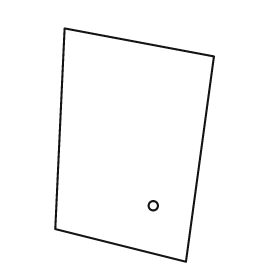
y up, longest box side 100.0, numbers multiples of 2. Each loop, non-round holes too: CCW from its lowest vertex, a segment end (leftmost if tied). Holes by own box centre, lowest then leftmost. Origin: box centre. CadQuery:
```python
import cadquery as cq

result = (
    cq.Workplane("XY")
    .moveTo(22.0, -50.0)
    .lineTo(34.0, 38.0)
    .lineTo(-30.0, 50.0)
    .lineTo(-34.0, -36.0)
    .close()
    .moveTo(8.0, -26.0)
    .circle(2.0)
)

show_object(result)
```